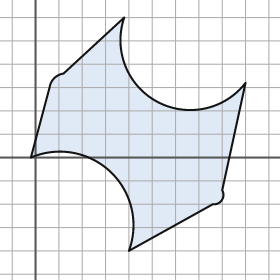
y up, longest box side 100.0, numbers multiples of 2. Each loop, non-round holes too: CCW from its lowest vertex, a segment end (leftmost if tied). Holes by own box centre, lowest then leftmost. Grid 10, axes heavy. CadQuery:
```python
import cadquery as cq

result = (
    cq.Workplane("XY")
    .moveTo(40.0, -40.0)
    .lineTo(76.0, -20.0)
    .threePointArc((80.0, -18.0), (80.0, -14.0))
    .lineTo(90.0, 32.0)
    .threePointArc((52.0, 24.0), (38.0, 60.0))
    .lineTo(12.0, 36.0)
    .threePointArc((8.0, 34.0), (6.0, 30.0))
    .lineTo(-2.0, 0.0)
    .threePointArc((32.0, -6.0), (40.0, -40.0))
    .close()
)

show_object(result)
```